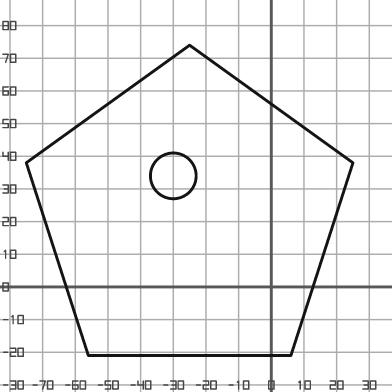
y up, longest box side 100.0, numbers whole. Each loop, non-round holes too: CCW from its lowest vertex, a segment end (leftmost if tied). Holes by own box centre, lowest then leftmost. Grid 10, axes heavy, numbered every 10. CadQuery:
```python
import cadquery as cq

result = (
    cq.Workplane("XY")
    .moveTo(-56.0, -21.0)
    .lineTo(6.0, -21.0)
    .lineTo(25.0, 38.0)
    .lineTo(-25.0, 74.0)
    .lineTo(-75.0, 38.0)
    .close()
    .moveTo(-30.0, 34.0)
    .circle(7.0)
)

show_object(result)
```